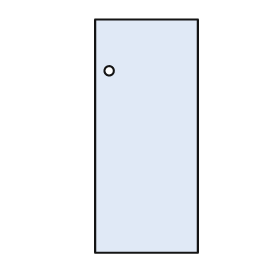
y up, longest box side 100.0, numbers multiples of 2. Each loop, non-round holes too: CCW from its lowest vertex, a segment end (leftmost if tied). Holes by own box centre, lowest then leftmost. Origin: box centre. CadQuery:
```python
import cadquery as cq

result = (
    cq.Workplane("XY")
    .moveTo(-22.0, -50.0)
    .lineTo(22.0, -50.0)
    .lineTo(22.0, 50.0)
    .lineTo(-22.0, 50.0)
    .close()
    .moveTo(-16.0, 28.0)
    .circle(2.0)
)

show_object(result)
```